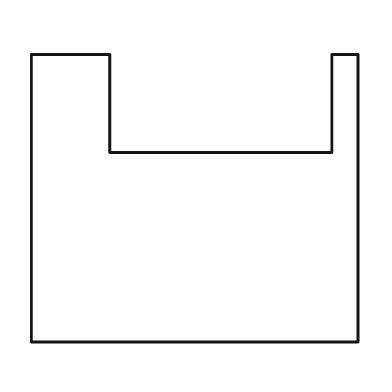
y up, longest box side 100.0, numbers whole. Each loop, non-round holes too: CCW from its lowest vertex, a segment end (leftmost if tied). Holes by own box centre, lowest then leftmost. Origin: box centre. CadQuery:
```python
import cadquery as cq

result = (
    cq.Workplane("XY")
    .moveTo(-50.0, -44.0)
    .lineTo(50.0, -44.0)
    .lineTo(50.0, 44.0)
    .lineTo(42.0, 44.0)
    .lineTo(42.0, 14.0)
    .lineTo(-26.0, 14.0)
    .lineTo(-26.0, 44.0)
    .lineTo(-50.0, 44.0)
    .close()
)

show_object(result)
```